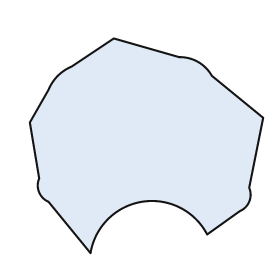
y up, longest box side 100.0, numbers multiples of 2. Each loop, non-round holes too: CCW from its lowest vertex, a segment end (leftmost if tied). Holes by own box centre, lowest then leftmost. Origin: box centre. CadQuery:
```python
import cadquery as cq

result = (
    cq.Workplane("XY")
    .moveTo(-24.0, -46.0)
    .threePointArc((-2.0, -24.0), (26.0, -38.0))
    .lineTo(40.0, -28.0)
    .threePointArc((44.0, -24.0), (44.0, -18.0))
    .lineTo(50.0, 12.0)
    .lineTo(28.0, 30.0)
    .threePointArc((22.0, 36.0), (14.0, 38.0))
    .lineTo(-14.0, 46.0)
    .lineTo(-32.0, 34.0)
    .threePointArc((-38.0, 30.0), (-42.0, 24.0))
    .lineTo(-50.0, 10.0)
    .lineTo(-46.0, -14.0)
    .threePointArc((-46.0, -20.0), (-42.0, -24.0))
    .close()
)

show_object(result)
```